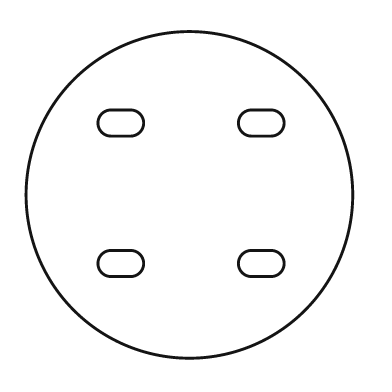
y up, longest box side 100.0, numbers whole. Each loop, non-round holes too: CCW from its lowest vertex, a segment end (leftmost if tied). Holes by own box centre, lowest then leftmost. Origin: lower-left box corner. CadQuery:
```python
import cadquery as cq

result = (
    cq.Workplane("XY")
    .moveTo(50.0, 50.0)
    .circle(50.0)
    .moveTo(26.0, 25.0)
    .lineTo(32.0, 25.0)
    .threePointArc((36.0, 29.0), (32.0, 33.0))
    .lineTo(26.0, 33.0)
    .threePointArc((22.0, 29.0), (26.0, 25.0))
    .close()
    .moveTo(69.0, 25.0)
    .lineTo(75.0, 25.0)
    .threePointArc((79.0, 29.0), (75.0, 33.0))
    .lineTo(69.0, 33.0)
    .threePointArc((65.0, 29.0), (69.0, 25.0))
    .close()
    .moveTo(26.0, 68.0)
    .lineTo(32.0, 68.0)
    .threePointArc((36.0, 72.0), (32.0, 76.0))
    .lineTo(26.0, 76.0)
    .threePointArc((22.0, 72.0), (26.0, 68.0))
    .close()
    .moveTo(69.0, 68.0)
    .lineTo(75.0, 68.0)
    .threePointArc((79.0, 72.0), (75.0, 76.0))
    .lineTo(69.0, 76.0)
    .threePointArc((65.0, 72.0), (69.0, 68.0))
    .close()
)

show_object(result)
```